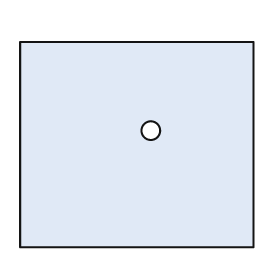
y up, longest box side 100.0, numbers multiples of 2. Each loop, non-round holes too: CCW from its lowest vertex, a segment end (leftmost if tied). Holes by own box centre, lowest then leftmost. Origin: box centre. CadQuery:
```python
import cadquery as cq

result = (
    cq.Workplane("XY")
    .moveTo(-50.0, -44.0)
    .lineTo(50.0, -44.0)
    .lineTo(50.0, 44.0)
    .lineTo(-50.0, 44.0)
    .close()
    .moveTo(6.0, 6.0)
    .circle(4.0)
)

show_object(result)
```